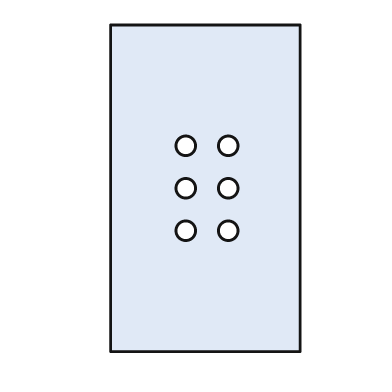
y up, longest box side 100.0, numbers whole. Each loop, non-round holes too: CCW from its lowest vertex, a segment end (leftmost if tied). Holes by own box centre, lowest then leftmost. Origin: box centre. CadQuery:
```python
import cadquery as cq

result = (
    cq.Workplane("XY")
    .moveTo(-29.0, -50.0)
    .lineTo(29.0, -50.0)
    .lineTo(29.0, 50.0)
    .lineTo(-29.0, 50.0)
    .close()
    .moveTo(-6.0, -13.0)
    .circle(3.0)
    .moveTo(7.0, -13.0)
    .circle(3.0)
    .moveTo(-6.0, 0.0)
    .circle(3.0)
    .moveTo(7.0, 0.0)
    .circle(3.0)
    .moveTo(-6.0, 13.0)
    .circle(3.0)
    .moveTo(7.0, 13.0)
    .circle(3.0)
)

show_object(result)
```